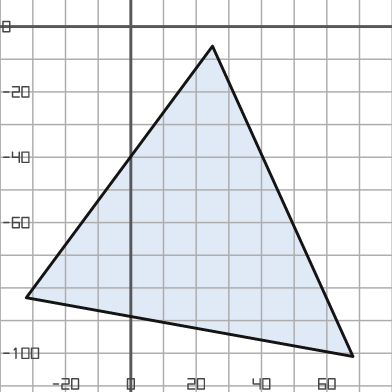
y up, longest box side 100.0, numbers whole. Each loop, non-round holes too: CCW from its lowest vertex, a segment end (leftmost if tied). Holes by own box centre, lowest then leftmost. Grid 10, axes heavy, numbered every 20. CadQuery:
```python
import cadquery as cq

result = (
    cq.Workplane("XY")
    .moveTo(68.0, -101.0)
    .lineTo(25.0, -6.0)
    .lineTo(-32.0, -83.0)
    .close()
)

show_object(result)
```